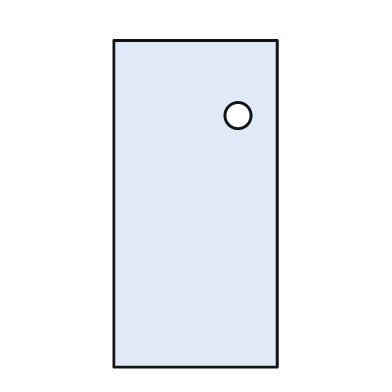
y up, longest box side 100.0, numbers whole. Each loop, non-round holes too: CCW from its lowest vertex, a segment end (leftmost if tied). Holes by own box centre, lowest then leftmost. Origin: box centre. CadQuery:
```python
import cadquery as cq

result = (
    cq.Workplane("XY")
    .moveTo(-25.0, -50.0)
    .lineTo(25.0, -50.0)
    .lineTo(25.0, 50.0)
    .lineTo(-25.0, 50.0)
    .close()
    .moveTo(13.0, 27.0)
    .circle(4.0)
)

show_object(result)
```